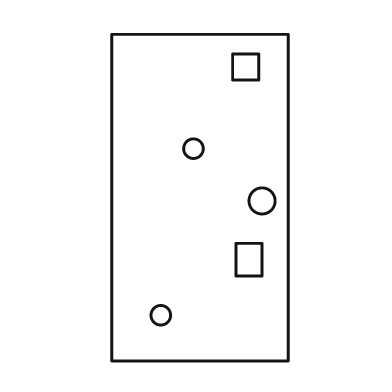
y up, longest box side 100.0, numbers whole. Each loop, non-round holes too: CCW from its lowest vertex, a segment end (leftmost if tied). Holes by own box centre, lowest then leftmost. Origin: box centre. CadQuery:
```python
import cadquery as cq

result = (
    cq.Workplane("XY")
    .moveTo(-27.0, -50.0)
    .lineTo(27.0, -50.0)
    .lineTo(27.0, 50.0)
    .lineTo(-27.0, 50.0)
    .close()
    .moveTo(-12.0, -36.0)
    .circle(3.0)
    .moveTo(11.0, -24.0)
    .lineTo(19.0, -24.0)
    .lineTo(19.0, -14.0)
    .lineTo(11.0, -14.0)
    .close()
    .moveTo(19.0, -1.0)
    .circle(4.0)
    .moveTo(-2.0, 15.0)
    .circle(3.0)
    .moveTo(10.0, 36.0)
    .lineTo(18.0, 36.0)
    .lineTo(18.0, 44.0)
    .lineTo(10.0, 44.0)
    .close()
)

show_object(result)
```